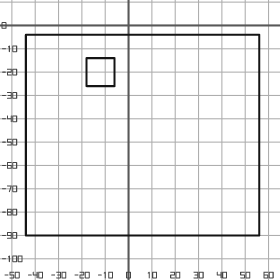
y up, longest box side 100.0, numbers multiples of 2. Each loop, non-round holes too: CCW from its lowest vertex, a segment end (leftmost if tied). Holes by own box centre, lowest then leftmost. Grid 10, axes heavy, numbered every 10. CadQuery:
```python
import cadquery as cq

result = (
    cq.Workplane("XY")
    .moveTo(-44.0, -90.0)
    .lineTo(56.0, -90.0)
    .lineTo(56.0, -4.0)
    .lineTo(-44.0, -4.0)
    .close()
    .moveTo(-18.0, -26.0)
    .lineTo(-6.0, -26.0)
    .lineTo(-6.0, -14.0)
    .lineTo(-18.0, -14.0)
    .close()
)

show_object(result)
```